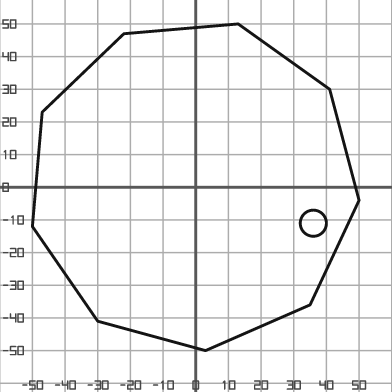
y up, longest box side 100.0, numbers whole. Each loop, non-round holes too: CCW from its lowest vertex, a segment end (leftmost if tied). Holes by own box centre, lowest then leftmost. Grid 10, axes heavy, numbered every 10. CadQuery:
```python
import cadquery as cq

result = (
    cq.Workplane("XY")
    .moveTo(3.0, -50.0)
    .lineTo(35.0, -36.0)
    .lineTo(50.0, -4.0)
    .lineTo(41.0, 30.0)
    .lineTo(13.0, 50.0)
    .lineTo(-22.0, 47.0)
    .lineTo(-47.0, 23.0)
    .lineTo(-50.0, -12.0)
    .lineTo(-30.0, -41.0)
    .close()
    .moveTo(36.0, -11.0)
    .circle(4.0)
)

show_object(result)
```